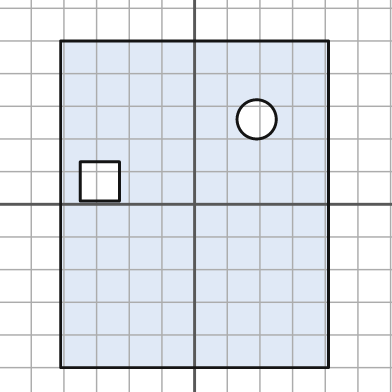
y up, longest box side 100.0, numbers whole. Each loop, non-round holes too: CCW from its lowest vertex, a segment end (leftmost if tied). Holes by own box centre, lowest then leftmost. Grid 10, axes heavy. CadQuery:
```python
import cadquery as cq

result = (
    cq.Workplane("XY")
    .moveTo(-41.0, -50.0)
    .lineTo(41.0, -50.0)
    .lineTo(41.0, 50.0)
    .lineTo(-41.0, 50.0)
    .close()
    .moveTo(-35.0, 1.0)
    .lineTo(-23.0, 1.0)
    .lineTo(-23.0, 13.0)
    .lineTo(-35.0, 13.0)
    .close()
    .moveTo(19.0, 26.0)
    .circle(6.0)
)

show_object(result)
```